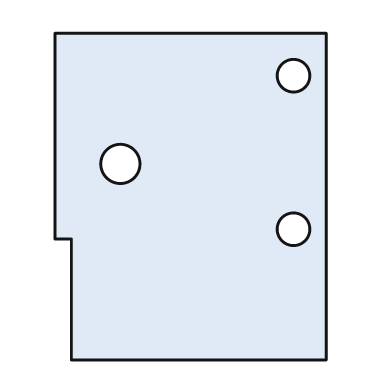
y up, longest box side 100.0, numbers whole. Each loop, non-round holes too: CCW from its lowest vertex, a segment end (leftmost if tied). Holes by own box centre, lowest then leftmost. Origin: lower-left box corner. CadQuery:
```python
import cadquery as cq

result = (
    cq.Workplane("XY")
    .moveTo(5.0, 0.0)
    .lineTo(83.0, 0.0)
    .lineTo(83.0, 100.0)
    .lineTo(0.0, 100.0)
    .lineTo(0.0, 37.0)
    .lineTo(5.0, 37.0)
    .close()
    .moveTo(73.0, 40.0)
    .circle(5.0)
    .moveTo(20.0, 60.0)
    .circle(6.0)
    .moveTo(73.0, 87.0)
    .circle(5.0)
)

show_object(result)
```